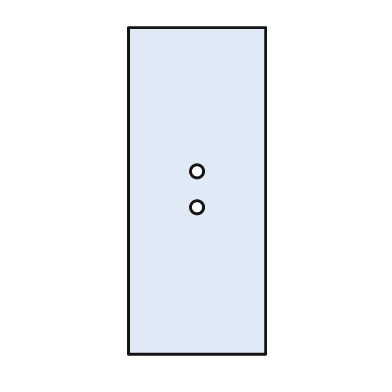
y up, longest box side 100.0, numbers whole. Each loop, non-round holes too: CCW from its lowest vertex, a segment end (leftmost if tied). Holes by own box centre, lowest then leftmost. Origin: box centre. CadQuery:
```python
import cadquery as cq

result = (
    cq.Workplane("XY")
    .moveTo(-21.0, -50.0)
    .lineTo(21.0, -50.0)
    .lineTo(21.0, 50.0)
    .lineTo(-21.0, 50.0)
    .close()
    .moveTo(0.0, -5.0)
    .circle(2.0)
    .moveTo(0.0, 6.0)
    .circle(2.0)
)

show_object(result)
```